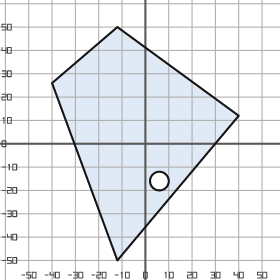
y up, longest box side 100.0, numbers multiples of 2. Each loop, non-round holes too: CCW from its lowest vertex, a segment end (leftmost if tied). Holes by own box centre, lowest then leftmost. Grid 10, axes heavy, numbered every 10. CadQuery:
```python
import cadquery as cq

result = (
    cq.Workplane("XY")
    .moveTo(-12.0, -50.0)
    .lineTo(40.0, 12.0)
    .lineTo(-12.0, 50.0)
    .lineTo(-40.0, 26.0)
    .close()
    .moveTo(6.0, -16.0)
    .circle(4.0)
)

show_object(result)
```